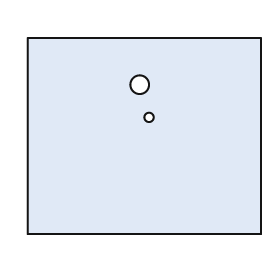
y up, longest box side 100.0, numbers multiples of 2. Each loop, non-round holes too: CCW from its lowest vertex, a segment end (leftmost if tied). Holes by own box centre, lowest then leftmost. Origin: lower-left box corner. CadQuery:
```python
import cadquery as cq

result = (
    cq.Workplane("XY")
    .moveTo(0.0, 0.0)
    .lineTo(100.0, 0.0)
    .lineTo(100.0, 84.0)
    .lineTo(0.0, 84.0)
    .close()
    .moveTo(52.0, 50.0)
    .circle(2.0)
    .moveTo(48.0, 64.0)
    .circle(4.0)
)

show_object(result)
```